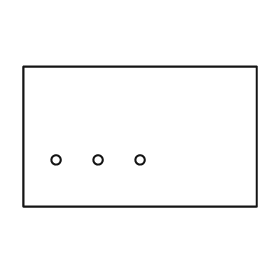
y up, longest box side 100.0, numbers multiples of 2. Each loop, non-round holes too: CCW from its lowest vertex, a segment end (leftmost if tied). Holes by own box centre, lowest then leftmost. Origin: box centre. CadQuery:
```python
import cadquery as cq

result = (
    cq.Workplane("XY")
    .moveTo(-50.0, -30.0)
    .lineTo(50.0, -30.0)
    .lineTo(50.0, 30.0)
    .lineTo(-50.0, 30.0)
    .close()
    .moveTo(-36.0, -10.0)
    .circle(2.0)
    .moveTo(-18.0, -10.0)
    .circle(2.0)
    .moveTo(0.0, -10.0)
    .circle(2.0)
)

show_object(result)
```